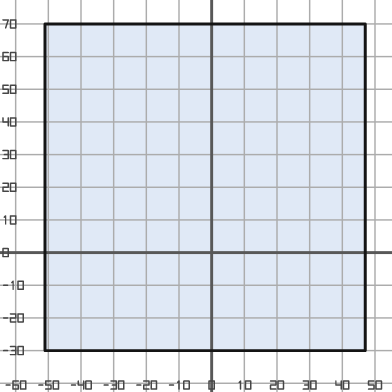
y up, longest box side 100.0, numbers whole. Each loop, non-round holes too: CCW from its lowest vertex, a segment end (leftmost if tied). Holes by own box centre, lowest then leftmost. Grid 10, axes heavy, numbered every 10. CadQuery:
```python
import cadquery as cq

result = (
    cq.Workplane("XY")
    .moveTo(-51.0, -30.0)
    .lineTo(47.0, -30.0)
    .lineTo(47.0, 70.0)
    .lineTo(-51.0, 70.0)
    .close()
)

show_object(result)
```